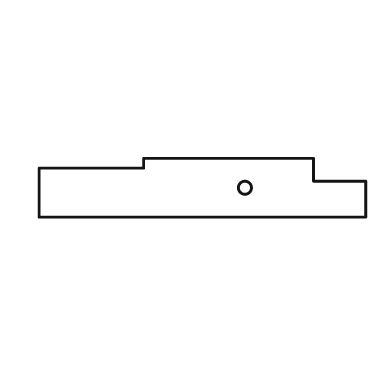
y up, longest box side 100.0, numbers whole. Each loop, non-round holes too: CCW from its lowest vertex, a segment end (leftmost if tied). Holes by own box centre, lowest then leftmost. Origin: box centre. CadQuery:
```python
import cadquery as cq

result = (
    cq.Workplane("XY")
    .moveTo(-50.0, -9.0)
    .lineTo(50.0, -9.0)
    .lineTo(50.0, 2.0)
    .lineTo(34.0, 2.0)
    .lineTo(34.0, 9.0)
    .lineTo(-18.0, 9.0)
    .lineTo(-18.0, 6.0)
    .lineTo(-50.0, 6.0)
    .close()
    .moveTo(13.0, 0.0)
    .circle(2.0)
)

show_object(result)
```